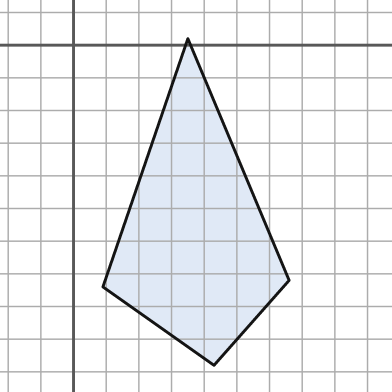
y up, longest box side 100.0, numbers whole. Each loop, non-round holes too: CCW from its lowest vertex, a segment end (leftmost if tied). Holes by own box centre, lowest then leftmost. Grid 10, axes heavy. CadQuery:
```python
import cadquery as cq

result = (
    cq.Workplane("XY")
    .moveTo(43.0, -98.0)
    .lineTo(66.0, -72.0)
    .lineTo(35.0, 2.0)
    .lineTo(9.0, -74.0)
    .close()
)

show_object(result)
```